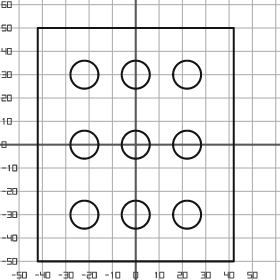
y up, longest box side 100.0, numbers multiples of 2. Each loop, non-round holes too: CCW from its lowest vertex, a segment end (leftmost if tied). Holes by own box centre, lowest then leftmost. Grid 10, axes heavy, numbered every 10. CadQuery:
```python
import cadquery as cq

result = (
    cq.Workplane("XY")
    .moveTo(-42.0, -50.0)
    .lineTo(42.0, -50.0)
    .lineTo(42.0, 50.0)
    .lineTo(-42.0, 50.0)
    .close()
    .moveTo(-22.0, -30.0)
    .circle(6.0)
    .moveTo(0.0, -30.0)
    .circle(6.0)
    .moveTo(22.0, -30.0)
    .circle(6.0)
    .moveTo(-22.0, 0.0)
    .circle(6.0)
    .moveTo(0.0, 0.0)
    .circle(6.0)
    .moveTo(22.0, 0.0)
    .circle(6.0)
    .moveTo(-22.0, 30.0)
    .circle(6.0)
    .moveTo(0.0, 30.0)
    .circle(6.0)
    .moveTo(22.0, 30.0)
    .circle(6.0)
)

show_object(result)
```